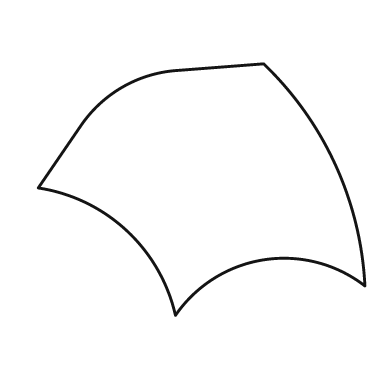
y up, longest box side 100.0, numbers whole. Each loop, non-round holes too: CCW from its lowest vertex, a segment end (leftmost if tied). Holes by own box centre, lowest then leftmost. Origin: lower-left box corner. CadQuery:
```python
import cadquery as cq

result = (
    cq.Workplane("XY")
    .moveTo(42.0, 0.0)
    .threePointArc((69.0, 17.0), (100.0, 9.0))
    .threePointArc((91.0, 46.0), (69.0, 77.0))
    .lineTo(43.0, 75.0)
    .threePointArc((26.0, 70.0), (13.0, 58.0))
    .lineTo(0.0, 39.0)
    .threePointArc((27.0, 26.0), (42.0, 0.0))
    .close()
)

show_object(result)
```